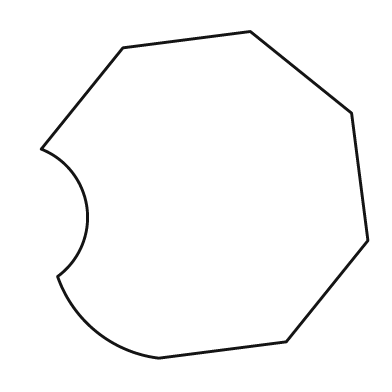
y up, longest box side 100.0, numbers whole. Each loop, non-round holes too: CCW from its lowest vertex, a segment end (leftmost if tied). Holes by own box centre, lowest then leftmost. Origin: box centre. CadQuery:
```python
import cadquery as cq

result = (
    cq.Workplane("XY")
    .moveTo(-14.0, -50.0)
    .lineTo(25.0, -45.0)
    .lineTo(50.0, -14.0)
    .lineTo(45.0, 25.0)
    .lineTo(14.0, 50.0)
    .lineTo(-25.0, 45.0)
    .lineTo(-50.0, 14.0)
    .threePointArc((-36.0, -4.0), (-45.0, -25.0))
    .threePointArc((-33.0, -42.0), (-14.0, -50.0))
    .close()
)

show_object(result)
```